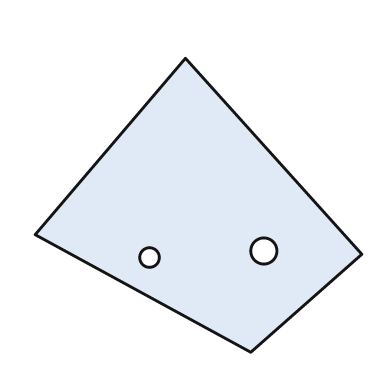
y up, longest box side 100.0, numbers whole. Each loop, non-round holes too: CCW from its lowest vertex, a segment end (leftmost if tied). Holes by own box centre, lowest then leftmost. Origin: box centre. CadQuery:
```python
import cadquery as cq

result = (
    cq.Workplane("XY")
    .moveTo(16.0, -45.0)
    .lineTo(50.0, -15.0)
    .lineTo(-4.0, 45.0)
    .lineTo(-50.0, -9.0)
    .close()
    .moveTo(-15.0, -16.0)
    .circle(3.0)
    .moveTo(20.0, -14.0)
    .circle(4.0)
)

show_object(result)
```